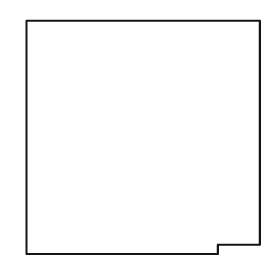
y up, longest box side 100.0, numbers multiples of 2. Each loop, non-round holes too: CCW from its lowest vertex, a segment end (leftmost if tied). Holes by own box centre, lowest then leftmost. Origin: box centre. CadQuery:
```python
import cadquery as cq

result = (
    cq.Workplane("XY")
    .moveTo(-50.0, -50.0)
    .lineTo(32.0, -50.0)
    .lineTo(32.0, -46.0)
    .lineTo(50.0, -46.0)
    .lineTo(50.0, 50.0)
    .lineTo(-50.0, 50.0)
    .close()
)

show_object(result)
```